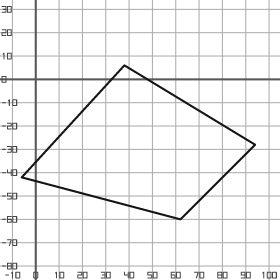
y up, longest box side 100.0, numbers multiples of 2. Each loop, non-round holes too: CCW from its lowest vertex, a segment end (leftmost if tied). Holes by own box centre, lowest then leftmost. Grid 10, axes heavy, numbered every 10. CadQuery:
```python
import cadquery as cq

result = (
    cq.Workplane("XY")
    .moveTo(62.0, -60.0)
    .lineTo(94.0, -28.0)
    .lineTo(38.0, 6.0)
    .lineTo(-6.0, -42.0)
    .close()
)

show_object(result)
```